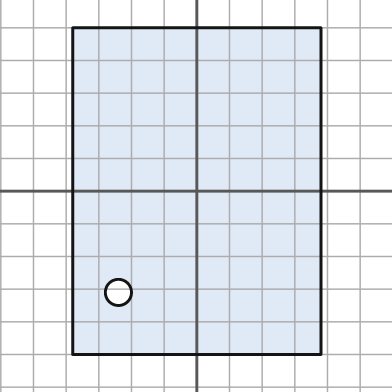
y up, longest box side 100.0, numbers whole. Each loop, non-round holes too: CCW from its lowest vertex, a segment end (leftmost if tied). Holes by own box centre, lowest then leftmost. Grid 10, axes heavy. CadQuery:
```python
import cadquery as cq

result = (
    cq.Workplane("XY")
    .moveTo(-38.0, -50.0)
    .lineTo(38.0, -50.0)
    .lineTo(38.0, 50.0)
    .lineTo(-38.0, 50.0)
    .close()
    .moveTo(-24.0, -31.0)
    .circle(4.0)
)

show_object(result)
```